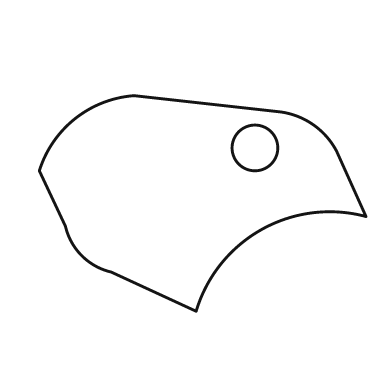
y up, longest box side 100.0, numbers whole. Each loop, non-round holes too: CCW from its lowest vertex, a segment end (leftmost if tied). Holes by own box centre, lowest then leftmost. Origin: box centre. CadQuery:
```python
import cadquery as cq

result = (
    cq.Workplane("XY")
    .moveTo(-2.0, -33.0)
    .threePointArc((18.0, -8.0), (50.0, -4.0))
    .lineTo(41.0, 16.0)
    .threePointArc((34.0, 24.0), (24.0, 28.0))
    .lineTo(-21.0, 33.0)
    .threePointArc((-39.0, 26.0), (-50.0, 10.0))
    .lineTo(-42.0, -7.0)
    .threePointArc((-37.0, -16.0), (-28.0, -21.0))
    .close()
    .moveTo(16.0, 17.0)
    .circle(7.0)
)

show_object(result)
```